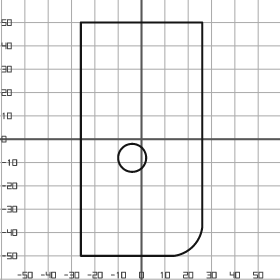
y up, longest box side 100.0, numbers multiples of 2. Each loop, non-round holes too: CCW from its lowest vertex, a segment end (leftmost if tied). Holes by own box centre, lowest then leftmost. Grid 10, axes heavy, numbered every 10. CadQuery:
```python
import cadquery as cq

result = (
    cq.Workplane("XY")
    .moveTo(-26.0, -50.0)
    .lineTo(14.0, -50.0)
    .threePointArc((22.0, -46.0), (26.0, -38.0))
    .lineTo(26.0, 50.0)
    .lineTo(-26.0, 50.0)
    .close()
    .moveTo(-4.0, -8.0)
    .circle(6.0)
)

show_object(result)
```